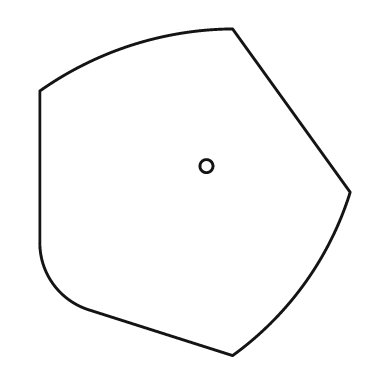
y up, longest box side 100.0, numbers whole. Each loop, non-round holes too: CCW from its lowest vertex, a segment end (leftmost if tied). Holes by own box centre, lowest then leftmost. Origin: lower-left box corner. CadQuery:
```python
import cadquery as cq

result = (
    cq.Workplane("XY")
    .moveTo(59.0, 0.0)
    .threePointArc((81.0, 22.0), (95.0, 50.0))
    .lineTo(59.0, 100.0)
    .threePointArc((28.0, 95.0), (0.0, 81.0))
    .lineTo(0.0, 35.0)
    .threePointArc((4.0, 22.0), (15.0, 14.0))
    .close()
    .moveTo(51.0, 58.0)
    .circle(2.0)
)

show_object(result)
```